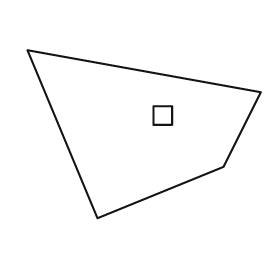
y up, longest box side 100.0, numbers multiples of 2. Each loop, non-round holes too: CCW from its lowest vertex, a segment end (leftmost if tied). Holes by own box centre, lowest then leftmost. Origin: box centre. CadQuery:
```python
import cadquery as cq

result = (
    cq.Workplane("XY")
    .moveTo(-20.0, -36.0)
    .lineTo(34.0, -14.0)
    .lineTo(50.0, 18.0)
    .lineTo(-50.0, 36.0)
    .close()
    .moveTo(4.0, 4.0)
    .lineTo(12.0, 4.0)
    .lineTo(12.0, 12.0)
    .lineTo(4.0, 12.0)
    .close()
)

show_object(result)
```